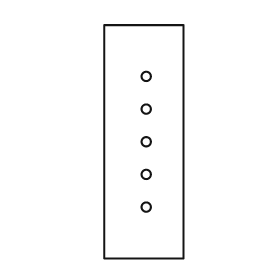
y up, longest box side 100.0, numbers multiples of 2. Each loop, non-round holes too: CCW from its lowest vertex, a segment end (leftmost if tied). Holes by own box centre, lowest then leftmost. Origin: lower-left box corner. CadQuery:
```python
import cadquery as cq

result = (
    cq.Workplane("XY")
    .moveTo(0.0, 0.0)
    .lineTo(34.0, 0.0)
    .lineTo(34.0, 100.0)
    .lineTo(0.0, 100.0)
    .close()
    .moveTo(18.0, 22.0)
    .circle(2.0)
    .moveTo(18.0, 36.0)
    .circle(2.0)
    .moveTo(18.0, 50.0)
    .circle(2.0)
    .moveTo(18.0, 64.0)
    .circle(2.0)
    .moveTo(18.0, 78.0)
    .circle(2.0)
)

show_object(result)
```